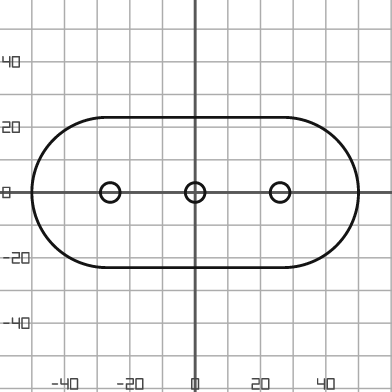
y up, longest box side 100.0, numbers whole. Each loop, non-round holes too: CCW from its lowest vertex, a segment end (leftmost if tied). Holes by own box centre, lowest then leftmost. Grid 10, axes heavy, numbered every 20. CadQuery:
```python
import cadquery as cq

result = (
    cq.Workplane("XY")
    .moveTo(-27.0, -23.0)
    .lineTo(27.0, -23.0)
    .threePointArc((50.0, 0.0), (27.0, 23.0))
    .lineTo(-27.0, 23.0)
    .threePointArc((-50.0, 0.0), (-27.0, -23.0))
    .close()
    .moveTo(-26.0, 0.0)
    .circle(3.0)
    .moveTo(0.0, 0.0)
    .circle(3.0)
    .moveTo(26.0, 0.0)
    .circle(3.0)
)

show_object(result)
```